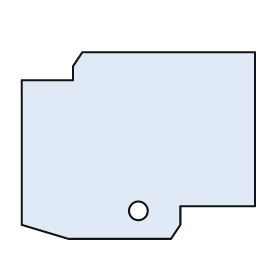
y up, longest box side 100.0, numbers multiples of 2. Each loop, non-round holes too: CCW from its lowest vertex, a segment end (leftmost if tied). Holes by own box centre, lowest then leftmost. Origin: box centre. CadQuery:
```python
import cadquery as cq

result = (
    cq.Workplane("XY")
    .moveTo(-30.0, -40.0)
    .lineTo(14.0, -40.0)
    .lineTo(18.0, -34.0)
    .lineTo(18.0, -26.0)
    .lineTo(50.0, -26.0)
    .lineTo(50.0, 40.0)
    .lineTo(-24.0, 40.0)
    .lineTo(-28.0, 34.0)
    .lineTo(-28.0, 28.0)
    .lineTo(-50.0, 28.0)
    .lineTo(-50.0, -34.0)
    .close()
    .moveTo(0.0, -28.0)
    .circle(4.0)
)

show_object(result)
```